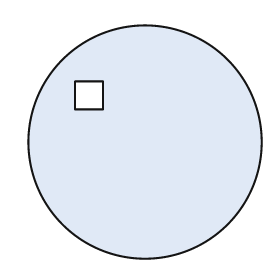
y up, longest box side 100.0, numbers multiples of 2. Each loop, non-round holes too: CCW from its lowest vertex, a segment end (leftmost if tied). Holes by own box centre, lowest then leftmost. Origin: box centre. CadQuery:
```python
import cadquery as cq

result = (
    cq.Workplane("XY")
    .moveTo(0.0, 0.0)
    .circle(50.0)
    .moveTo(-30.0, 14.0)
    .lineTo(-18.0, 14.0)
    .lineTo(-18.0, 26.0)
    .lineTo(-30.0, 26.0)
    .close()
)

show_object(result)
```